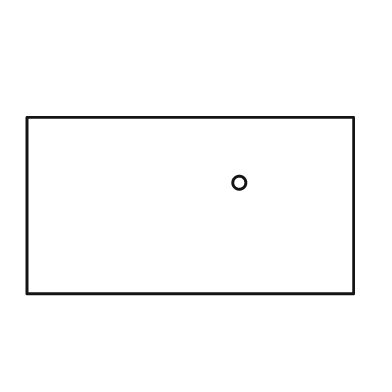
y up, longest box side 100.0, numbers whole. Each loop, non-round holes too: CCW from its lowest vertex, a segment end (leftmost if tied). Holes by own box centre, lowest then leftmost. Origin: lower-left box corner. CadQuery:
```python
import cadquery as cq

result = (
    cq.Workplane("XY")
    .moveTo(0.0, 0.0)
    .lineTo(100.0, 0.0)
    .lineTo(100.0, 54.0)
    .lineTo(0.0, 54.0)
    .close()
    .moveTo(65.0, 34.0)
    .circle(2.0)
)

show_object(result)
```